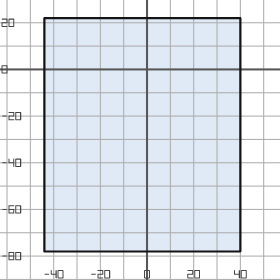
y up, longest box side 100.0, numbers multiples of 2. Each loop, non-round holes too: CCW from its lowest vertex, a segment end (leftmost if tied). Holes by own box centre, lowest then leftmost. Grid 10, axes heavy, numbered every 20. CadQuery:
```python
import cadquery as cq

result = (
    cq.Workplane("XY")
    .moveTo(-44.0, -78.0)
    .lineTo(40.0, -78.0)
    .lineTo(40.0, 22.0)
    .lineTo(-44.0, 22.0)
    .close()
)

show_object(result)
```